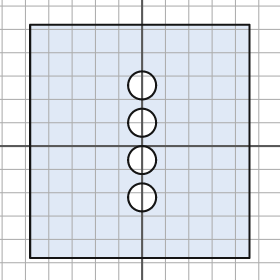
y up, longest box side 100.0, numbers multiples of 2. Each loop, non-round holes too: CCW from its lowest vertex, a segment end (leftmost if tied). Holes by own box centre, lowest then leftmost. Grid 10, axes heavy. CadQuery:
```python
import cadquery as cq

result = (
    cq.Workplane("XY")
    .moveTo(-48.0, -48.0)
    .lineTo(46.0, -48.0)
    .lineTo(46.0, 52.0)
    .lineTo(-48.0, 52.0)
    .close()
    .moveTo(0.0, -22.0)
    .circle(6.0)
    .moveTo(0.0, -6.0)
    .circle(6.0)
    .moveTo(0.0, 10.0)
    .circle(6.0)
    .moveTo(0.0, 26.0)
    .circle(6.0)
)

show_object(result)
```